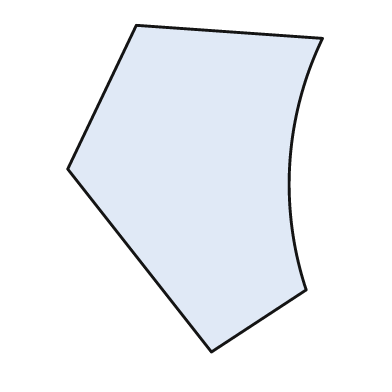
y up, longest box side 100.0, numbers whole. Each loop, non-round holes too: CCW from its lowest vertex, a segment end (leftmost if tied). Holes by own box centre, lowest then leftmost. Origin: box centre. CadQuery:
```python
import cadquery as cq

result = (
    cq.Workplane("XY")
    .moveTo(5.0, -50.0)
    .lineTo(34.0, -31.0)
    .threePointArc((29.0, 8.0), (39.0, 46.0))
    .lineTo(-18.0, 50.0)
    .lineTo(-39.0, 6.0)
    .close()
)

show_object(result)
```